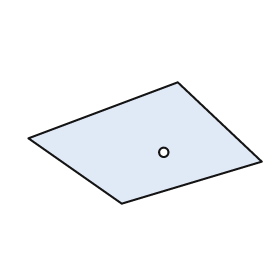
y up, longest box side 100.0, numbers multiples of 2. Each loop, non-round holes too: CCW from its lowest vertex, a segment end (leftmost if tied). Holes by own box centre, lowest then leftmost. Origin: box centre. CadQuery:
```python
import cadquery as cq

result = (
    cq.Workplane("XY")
    .moveTo(-10.0, -26.0)
    .lineTo(50.0, -8.0)
    .lineTo(14.0, 26.0)
    .lineTo(-50.0, 2.0)
    .close()
    .moveTo(8.0, -4.0)
    .circle(2.0)
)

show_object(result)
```